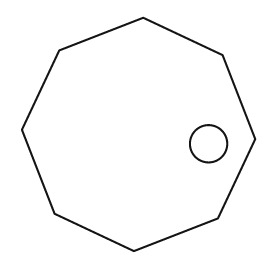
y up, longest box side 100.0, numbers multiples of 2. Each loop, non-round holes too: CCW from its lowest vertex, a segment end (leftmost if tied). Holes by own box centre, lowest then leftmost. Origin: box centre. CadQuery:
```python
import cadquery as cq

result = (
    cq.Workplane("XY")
    .moveTo(-2.0, -50.0)
    .lineTo(34.0, -36.0)
    .lineTo(50.0, -2.0)
    .lineTo(36.0, 34.0)
    .lineTo(2.0, 50.0)
    .lineTo(-34.0, 36.0)
    .lineTo(-50.0, 2.0)
    .lineTo(-36.0, -34.0)
    .close()
    .moveTo(30.0, -4.0)
    .circle(8.0)
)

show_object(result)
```